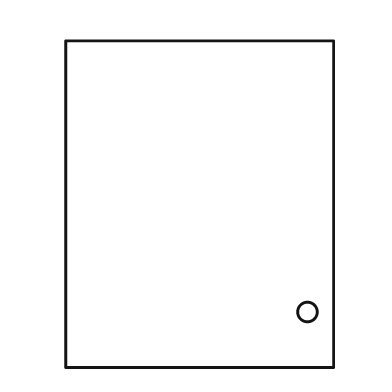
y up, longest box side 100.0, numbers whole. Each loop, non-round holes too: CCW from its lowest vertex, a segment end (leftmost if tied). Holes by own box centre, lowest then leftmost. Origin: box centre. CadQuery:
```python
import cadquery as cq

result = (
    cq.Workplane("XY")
    .moveTo(-41.0, -50.0)
    .lineTo(41.0, -50.0)
    .lineTo(41.0, 50.0)
    .lineTo(-41.0, 50.0)
    .close()
    .moveTo(33.0, -33.0)
    .circle(3.0)
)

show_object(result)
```